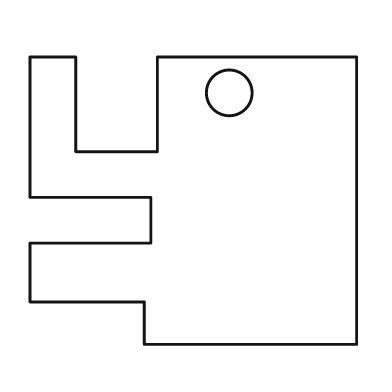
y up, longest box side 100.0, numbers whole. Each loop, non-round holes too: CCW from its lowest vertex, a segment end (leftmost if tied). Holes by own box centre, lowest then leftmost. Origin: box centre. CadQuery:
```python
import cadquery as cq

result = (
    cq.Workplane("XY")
    .moveTo(-15.0, -44.0)
    .lineTo(50.0, -44.0)
    .lineTo(50.0, 44.0)
    .lineTo(-11.0, 44.0)
    .lineTo(-11.0, 15.0)
    .lineTo(-36.0, 15.0)
    .lineTo(-36.0, 44.0)
    .lineTo(-50.0, 44.0)
    .lineTo(-50.0, 1.0)
    .lineTo(-13.0, 1.0)
    .lineTo(-13.0, -13.0)
    .lineTo(-50.0, -13.0)
    .lineTo(-50.0, -31.0)
    .lineTo(-15.0, -31.0)
    .close()
    .moveTo(11.0, 33.0)
    .circle(7.0)
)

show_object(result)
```